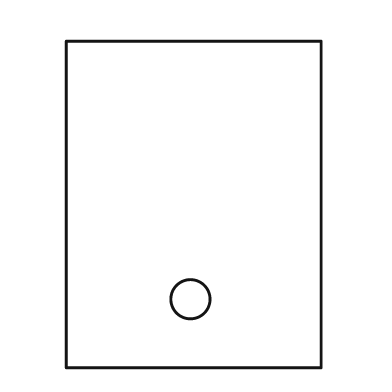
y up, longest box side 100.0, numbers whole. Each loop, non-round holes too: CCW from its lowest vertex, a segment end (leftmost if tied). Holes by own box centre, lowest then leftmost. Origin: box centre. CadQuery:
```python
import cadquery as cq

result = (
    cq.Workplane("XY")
    .moveTo(-39.0, -50.0)
    .lineTo(39.0, -50.0)
    .lineTo(39.0, 50.0)
    .lineTo(-39.0, 50.0)
    .close()
    .moveTo(-1.0, -29.0)
    .circle(6.0)
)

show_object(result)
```